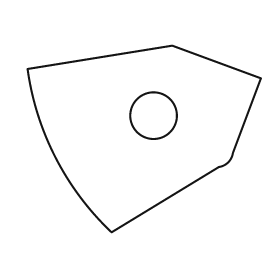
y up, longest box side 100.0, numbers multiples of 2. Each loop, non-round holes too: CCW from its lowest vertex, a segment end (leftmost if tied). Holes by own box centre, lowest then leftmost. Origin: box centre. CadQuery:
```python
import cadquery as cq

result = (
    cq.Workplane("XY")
    .moveTo(-14.0, -40.0)
    .lineTo(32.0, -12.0)
    .threePointArc((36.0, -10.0), (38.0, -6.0))
    .lineTo(50.0, 26.0)
    .lineTo(12.0, 40.0)
    .lineTo(-50.0, 30.0)
    .threePointArc((-38.0, -8.0), (-14.0, -40.0))
    .close()
    .moveTo(4.0, 10.0)
    .circle(10.0)
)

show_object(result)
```